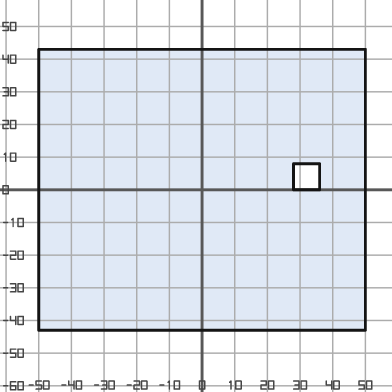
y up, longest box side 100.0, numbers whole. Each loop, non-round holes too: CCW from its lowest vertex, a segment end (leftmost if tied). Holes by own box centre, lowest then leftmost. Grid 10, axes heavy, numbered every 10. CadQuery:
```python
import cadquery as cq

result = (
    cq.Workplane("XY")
    .moveTo(-50.0, -43.0)
    .lineTo(50.0, -43.0)
    .lineTo(50.0, 43.0)
    .lineTo(-50.0, 43.0)
    .close()
    .moveTo(28.0, 0.0)
    .lineTo(36.0, 0.0)
    .lineTo(36.0, 8.0)
    .lineTo(28.0, 8.0)
    .close()
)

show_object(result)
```